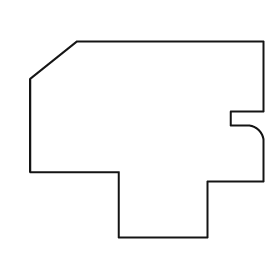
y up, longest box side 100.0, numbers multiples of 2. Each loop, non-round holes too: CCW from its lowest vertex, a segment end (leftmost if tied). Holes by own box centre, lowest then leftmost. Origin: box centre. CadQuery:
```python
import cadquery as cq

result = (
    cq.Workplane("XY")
    .moveTo(-12.0, -42.0)
    .lineTo(26.0, -42.0)
    .lineTo(26.0, -18.0)
    .lineTo(50.0, -18.0)
    .lineTo(50.0, 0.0)
    .threePointArc((48.0, 4.0), (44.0, 6.0))
    .lineTo(36.0, 6.0)
    .lineTo(36.0, 12.0)
    .lineTo(50.0, 12.0)
    .lineTo(50.0, 42.0)
    .lineTo(-30.0, 42.0)
    .lineTo(-50.0, 26.0)
    .lineTo(-50.0, -14.0)
    .lineTo(-12.0, -14.0)
    .close()
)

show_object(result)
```